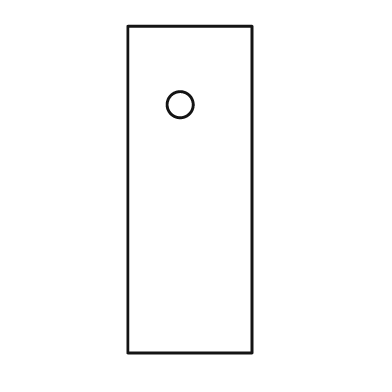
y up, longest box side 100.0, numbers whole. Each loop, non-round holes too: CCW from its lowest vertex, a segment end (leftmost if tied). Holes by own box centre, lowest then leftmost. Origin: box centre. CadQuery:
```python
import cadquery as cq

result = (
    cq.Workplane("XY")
    .moveTo(-19.0, -50.0)
    .lineTo(19.0, -50.0)
    .lineTo(19.0, 50.0)
    .lineTo(-19.0, 50.0)
    .close()
    .moveTo(-3.0, 26.0)
    .circle(4.0)
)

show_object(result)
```